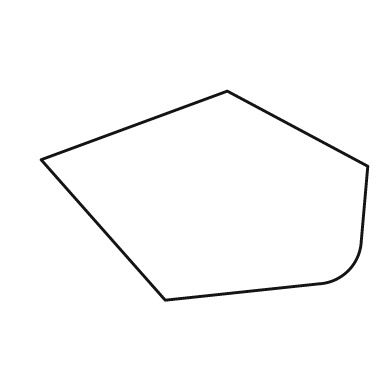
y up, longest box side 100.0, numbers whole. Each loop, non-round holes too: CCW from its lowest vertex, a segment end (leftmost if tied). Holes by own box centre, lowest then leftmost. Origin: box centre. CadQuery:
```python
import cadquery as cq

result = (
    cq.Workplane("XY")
    .moveTo(-12.0, -32.0)
    .lineTo(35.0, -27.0)
    .threePointArc((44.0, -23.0), (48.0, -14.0))
    .lineTo(50.0, 9.0)
    .lineTo(7.0, 32.0)
    .lineTo(-50.0, 11.0)
    .close()
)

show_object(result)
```